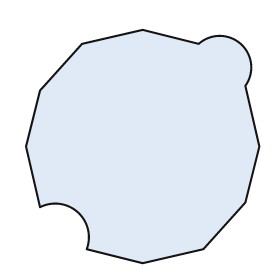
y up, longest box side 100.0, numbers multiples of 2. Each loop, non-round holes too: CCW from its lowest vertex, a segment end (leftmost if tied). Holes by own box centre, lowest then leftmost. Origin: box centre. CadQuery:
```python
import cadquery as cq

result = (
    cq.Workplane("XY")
    .moveTo(0.0, -50.0)
    .lineTo(26.0, -44.0)
    .lineTo(44.0, -24.0)
    .lineTo(50.0, 0.0)
    .lineTo(44.0, 26.0)
    .threePointArc((42.0, 44.0), (24.0, 44.0))
    .lineTo(0.0, 50.0)
    .lineTo(-26.0, 44.0)
    .lineTo(-44.0, 24.0)
    .lineTo(-50.0, 0.0)
    .lineTo(-44.0, -26.0)
    .threePointArc((-28.0, -28.0), (-24.0, -44.0))
    .close()
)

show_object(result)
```